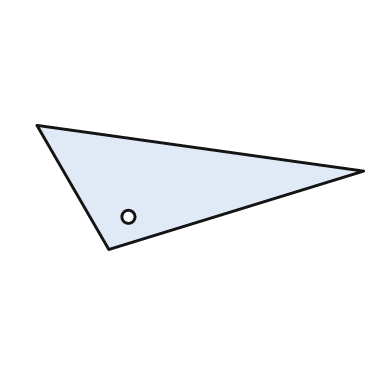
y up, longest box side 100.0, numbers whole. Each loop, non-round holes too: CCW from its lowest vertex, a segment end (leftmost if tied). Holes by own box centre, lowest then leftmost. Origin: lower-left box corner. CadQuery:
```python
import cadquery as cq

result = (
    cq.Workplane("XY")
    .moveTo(22.0, 0.0)
    .lineTo(100.0, 24.0)
    .lineTo(0.0, 38.0)
    .close()
    .moveTo(28.0, 10.0)
    .circle(2.0)
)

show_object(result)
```